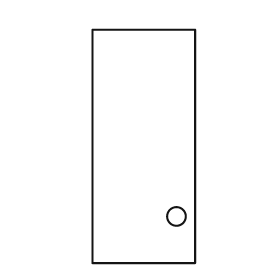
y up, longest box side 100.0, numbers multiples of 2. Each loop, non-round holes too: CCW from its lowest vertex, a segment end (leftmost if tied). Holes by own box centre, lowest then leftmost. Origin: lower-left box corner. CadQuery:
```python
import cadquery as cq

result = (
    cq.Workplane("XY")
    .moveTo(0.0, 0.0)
    .lineTo(44.0, 0.0)
    .lineTo(44.0, 100.0)
    .lineTo(0.0, 100.0)
    .close()
    .moveTo(36.0, 20.0)
    .circle(4.0)
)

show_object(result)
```